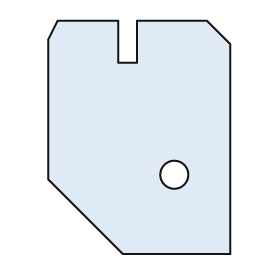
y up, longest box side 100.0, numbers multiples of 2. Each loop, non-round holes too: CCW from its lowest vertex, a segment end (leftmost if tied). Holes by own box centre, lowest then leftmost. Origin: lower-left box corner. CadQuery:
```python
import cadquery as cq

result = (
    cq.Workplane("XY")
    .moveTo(32.0, 0.0)
    .lineTo(78.0, 0.0)
    .lineTo(78.0, 90.0)
    .lineTo(68.0, 100.0)
    .lineTo(38.0, 100.0)
    .lineTo(38.0, 82.0)
    .lineTo(30.0, 82.0)
    .lineTo(30.0, 100.0)
    .lineTo(4.0, 100.0)
    .lineTo(0.0, 92.0)
    .lineTo(0.0, 32.0)
    .close()
    .moveTo(54.0, 34.0)
    .circle(6.0)
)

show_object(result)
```